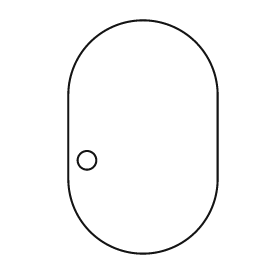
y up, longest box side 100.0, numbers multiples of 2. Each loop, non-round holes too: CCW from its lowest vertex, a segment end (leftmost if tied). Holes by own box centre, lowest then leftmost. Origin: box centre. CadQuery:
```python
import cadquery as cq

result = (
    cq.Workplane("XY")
    .moveTo(-32.0, -18.0)
    .threePointArc((0.0, -50.0), (32.0, -18.0))
    .lineTo(32.0, 18.0)
    .threePointArc((0.0, 50.0), (-32.0, 18.0))
    .close()
    .moveTo(-24.0, -10.0)
    .circle(4.0)
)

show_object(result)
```